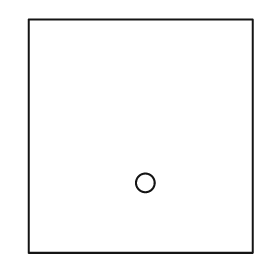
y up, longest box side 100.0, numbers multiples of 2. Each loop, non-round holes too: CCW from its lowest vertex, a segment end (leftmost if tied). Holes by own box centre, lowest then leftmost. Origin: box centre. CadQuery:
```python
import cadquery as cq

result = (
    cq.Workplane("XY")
    .moveTo(-48.0, -50.0)
    .lineTo(48.0, -50.0)
    .lineTo(48.0, 50.0)
    .lineTo(-48.0, 50.0)
    .close()
    .moveTo(2.0, -20.0)
    .circle(4.0)
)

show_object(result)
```